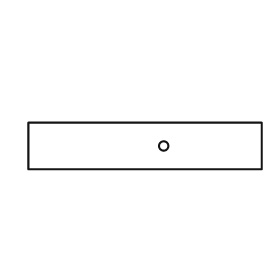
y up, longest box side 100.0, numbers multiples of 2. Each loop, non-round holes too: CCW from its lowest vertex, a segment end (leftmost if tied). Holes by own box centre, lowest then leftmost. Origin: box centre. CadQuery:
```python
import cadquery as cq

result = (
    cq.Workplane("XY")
    .moveTo(-50.0, -10.0)
    .lineTo(50.0, -10.0)
    .lineTo(50.0, 10.0)
    .lineTo(-50.0, 10.0)
    .close()
    .moveTo(8.0, 0.0)
    .circle(2.0)
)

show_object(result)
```